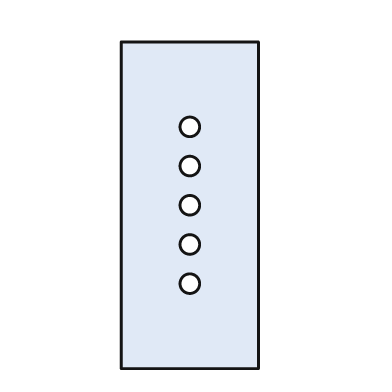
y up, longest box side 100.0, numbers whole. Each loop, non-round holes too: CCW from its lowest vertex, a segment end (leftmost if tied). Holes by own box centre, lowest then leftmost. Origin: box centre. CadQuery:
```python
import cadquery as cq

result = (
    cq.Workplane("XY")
    .moveTo(-21.0, -50.0)
    .lineTo(21.0, -50.0)
    .lineTo(21.0, 50.0)
    .lineTo(-21.0, 50.0)
    .close()
    .moveTo(0.0, -24.0)
    .circle(3.0)
    .moveTo(0.0, -12.0)
    .circle(3.0)
    .moveTo(0.0, 0.0)
    .circle(3.0)
    .moveTo(0.0, 12.0)
    .circle(3.0)
    .moveTo(0.0, 24.0)
    .circle(3.0)
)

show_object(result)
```